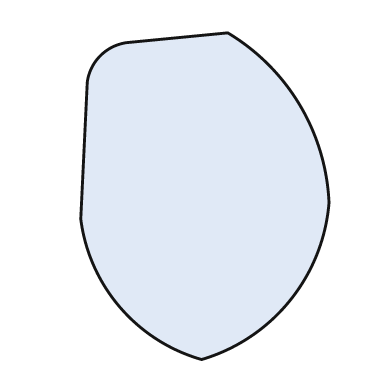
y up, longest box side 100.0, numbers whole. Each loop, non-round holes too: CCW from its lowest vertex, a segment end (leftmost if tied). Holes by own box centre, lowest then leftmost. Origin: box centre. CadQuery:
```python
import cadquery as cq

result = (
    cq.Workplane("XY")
    .moveTo(-1.0, -50.0)
    .threePointArc((26.0, -32.0), (38.0, -2.0))
    .threePointArc((29.0, 28.0), (7.0, 50.0))
    .lineTo(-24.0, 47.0)
    .threePointArc((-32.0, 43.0), (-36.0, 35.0))
    .lineTo(-38.0, -7.0)
    .threePointArc((-26.0, -34.0), (-1.0, -50.0))
    .close()
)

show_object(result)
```